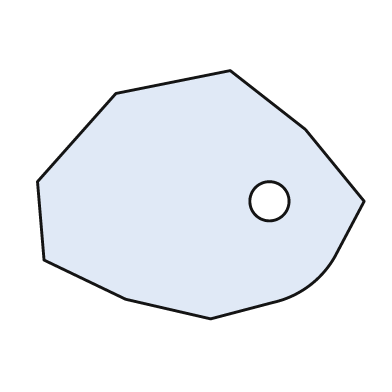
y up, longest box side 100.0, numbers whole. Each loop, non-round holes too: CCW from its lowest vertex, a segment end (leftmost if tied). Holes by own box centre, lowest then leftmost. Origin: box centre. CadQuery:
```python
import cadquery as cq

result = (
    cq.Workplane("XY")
    .moveTo(3.0, -38.0)
    .lineTo(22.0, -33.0)
    .threePointArc((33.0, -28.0), (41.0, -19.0))
    .lineTo(50.0, -2.0)
    .lineTo(32.0, 20.0)
    .lineTo(9.0, 38.0)
    .lineTo(-26.0, 31.0)
    .lineTo(-50.0, 4.0)
    .lineTo(-48.0, -20.0)
    .lineTo(-23.0, -32.0)
    .close()
    .moveTo(21.0, -2.0)
    .circle(6.0)
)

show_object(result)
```